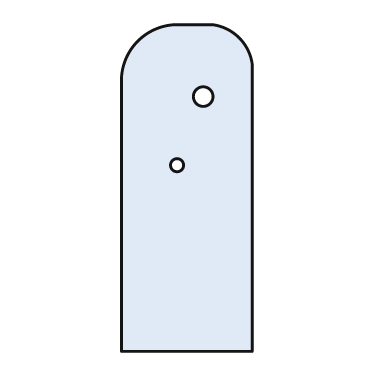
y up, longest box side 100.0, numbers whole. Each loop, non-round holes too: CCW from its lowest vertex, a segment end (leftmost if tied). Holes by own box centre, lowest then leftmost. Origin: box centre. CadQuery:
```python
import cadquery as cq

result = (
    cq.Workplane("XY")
    .moveTo(-20.0, -50.0)
    .lineTo(20.0, -50.0)
    .lineTo(20.0, 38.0)
    .threePointArc((16.0, 46.0), (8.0, 50.0))
    .lineTo(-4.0, 50.0)
    .threePointArc((-15.0, 45.0), (-20.0, 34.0))
    .close()
    .moveTo(-3.0, 7.0)
    .circle(2.0)
    .moveTo(5.0, 28.0)
    .circle(3.0)
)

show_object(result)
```